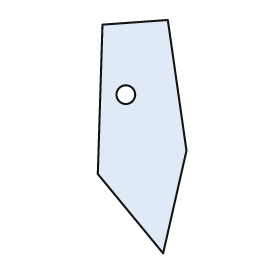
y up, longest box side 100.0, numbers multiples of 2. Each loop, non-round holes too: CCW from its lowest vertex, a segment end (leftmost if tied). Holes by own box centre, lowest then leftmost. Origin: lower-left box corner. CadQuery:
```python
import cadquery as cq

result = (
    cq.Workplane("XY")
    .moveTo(28.0, 0.0)
    .lineTo(38.0, 44.0)
    .lineTo(30.0, 100.0)
    .lineTo(2.0, 98.0)
    .lineTo(0.0, 34.0)
    .close()
    .moveTo(12.0, 68.0)
    .circle(4.0)
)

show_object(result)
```